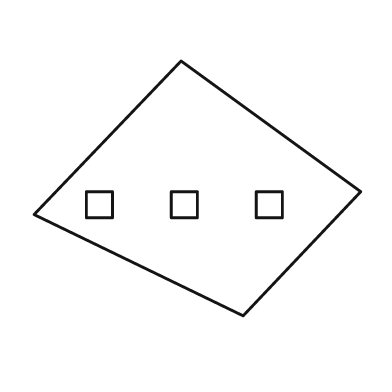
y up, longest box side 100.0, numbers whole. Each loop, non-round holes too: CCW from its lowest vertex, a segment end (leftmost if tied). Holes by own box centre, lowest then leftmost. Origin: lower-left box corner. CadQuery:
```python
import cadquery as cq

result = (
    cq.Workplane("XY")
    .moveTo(64.0, 0.0)
    .lineTo(100.0, 38.0)
    .lineTo(45.0, 78.0)
    .lineTo(0.0, 31.0)
    .close()
    .moveTo(16.0, 30.0)
    .lineTo(24.0, 30.0)
    .lineTo(24.0, 38.0)
    .lineTo(16.0, 38.0)
    .close()
    .moveTo(42.0, 30.0)
    .lineTo(50.0, 30.0)
    .lineTo(50.0, 38.0)
    .lineTo(42.0, 38.0)
    .close()
    .moveTo(68.0, 30.0)
    .lineTo(76.0, 30.0)
    .lineTo(76.0, 38.0)
    .lineTo(68.0, 38.0)
    .close()
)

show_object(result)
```